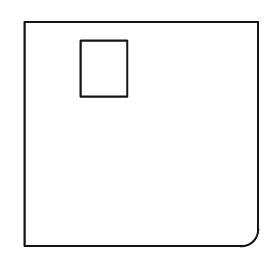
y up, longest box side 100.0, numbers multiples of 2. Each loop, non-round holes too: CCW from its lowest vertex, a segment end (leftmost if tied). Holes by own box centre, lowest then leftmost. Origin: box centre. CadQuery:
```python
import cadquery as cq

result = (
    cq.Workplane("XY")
    .moveTo(-50.0, -48.0)
    .lineTo(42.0, -48.0)
    .threePointArc((48.0, -46.0), (50.0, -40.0))
    .lineTo(50.0, 48.0)
    .lineTo(-50.0, 48.0)
    .close()
    .moveTo(-26.0, 16.0)
    .lineTo(-6.0, 16.0)
    .lineTo(-6.0, 40.0)
    .lineTo(-26.0, 40.0)
    .close()
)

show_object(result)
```